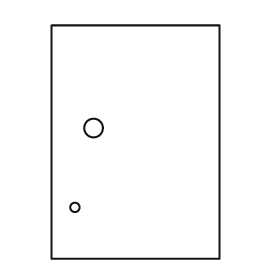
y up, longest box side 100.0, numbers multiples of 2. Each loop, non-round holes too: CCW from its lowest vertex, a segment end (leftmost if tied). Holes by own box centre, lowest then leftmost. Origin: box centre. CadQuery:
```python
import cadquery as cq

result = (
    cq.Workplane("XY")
    .moveTo(-36.0, -50.0)
    .lineTo(36.0, -50.0)
    .lineTo(36.0, 50.0)
    .lineTo(-36.0, 50.0)
    .close()
    .moveTo(-26.0, -28.0)
    .circle(2.0)
    .moveTo(-18.0, 6.0)
    .circle(4.0)
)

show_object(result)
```